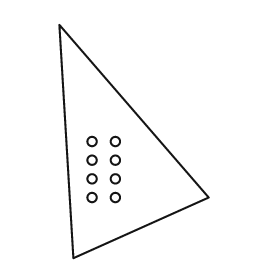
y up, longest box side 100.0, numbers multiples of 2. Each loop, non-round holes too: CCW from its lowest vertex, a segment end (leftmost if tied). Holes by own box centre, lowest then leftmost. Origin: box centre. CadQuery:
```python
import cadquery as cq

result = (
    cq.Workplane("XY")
    .moveTo(-26.0, -50.0)
    .lineTo(32.0, -24.0)
    .lineTo(-32.0, 50.0)
    .close()
    .moveTo(-18.0, -24.0)
    .circle(2.0)
    .moveTo(-8.0, -24.0)
    .circle(2.0)
    .moveTo(-18.0, -16.0)
    .circle(2.0)
    .moveTo(-8.0, -16.0)
    .circle(2.0)
    .moveTo(-18.0, -8.0)
    .circle(2.0)
    .moveTo(-8.0, -8.0)
    .circle(2.0)
    .moveTo(-18.0, 0.0)
    .circle(2.0)
    .moveTo(-8.0, 0.0)
    .circle(2.0)
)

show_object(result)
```